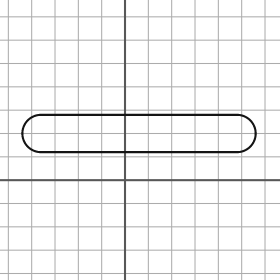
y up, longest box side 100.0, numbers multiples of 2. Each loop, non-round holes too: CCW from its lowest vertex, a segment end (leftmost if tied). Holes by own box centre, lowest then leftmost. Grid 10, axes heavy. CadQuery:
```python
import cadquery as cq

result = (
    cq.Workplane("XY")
    .moveTo(-36.0, 12.0)
    .lineTo(48.0, 12.0)
    .threePointArc((56.0, 20.0), (48.0, 28.0))
    .lineTo(-36.0, 28.0)
    .threePointArc((-44.0, 20.0), (-36.0, 12.0))
    .close()
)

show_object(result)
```